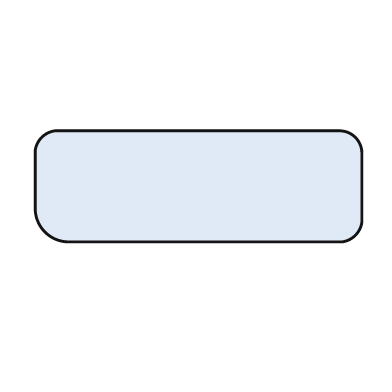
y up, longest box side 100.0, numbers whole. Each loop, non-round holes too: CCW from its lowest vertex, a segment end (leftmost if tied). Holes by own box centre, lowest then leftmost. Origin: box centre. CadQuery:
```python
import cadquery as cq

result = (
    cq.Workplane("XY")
    .moveTo(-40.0, -17.0)
    .lineTo(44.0, -17.0)
    .threePointArc((48.0, -15.0), (50.0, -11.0))
    .lineTo(50.0, 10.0)
    .threePointArc((48.0, 15.0), (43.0, 17.0))
    .lineTo(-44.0, 17.0)
    .threePointArc((-48.0, 15.0), (-50.0, 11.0))
    .lineTo(-50.0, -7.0)
    .threePointArc((-47.0, -14.0), (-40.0, -17.0))
    .close()
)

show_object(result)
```